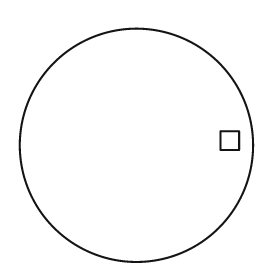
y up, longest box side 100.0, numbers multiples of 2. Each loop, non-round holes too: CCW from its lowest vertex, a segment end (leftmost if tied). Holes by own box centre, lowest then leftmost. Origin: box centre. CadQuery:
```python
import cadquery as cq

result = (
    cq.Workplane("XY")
    .moveTo(0.0, 0.0)
    .circle(50.0)
    .moveTo(36.0, -2.0)
    .lineTo(44.0, -2.0)
    .lineTo(44.0, 6.0)
    .lineTo(36.0, 6.0)
    .close()
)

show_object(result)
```